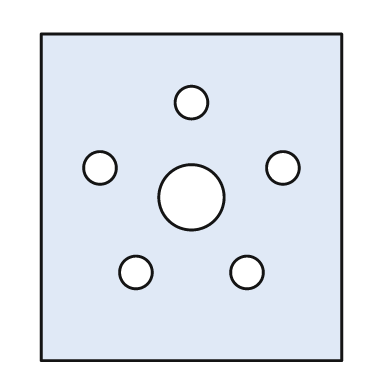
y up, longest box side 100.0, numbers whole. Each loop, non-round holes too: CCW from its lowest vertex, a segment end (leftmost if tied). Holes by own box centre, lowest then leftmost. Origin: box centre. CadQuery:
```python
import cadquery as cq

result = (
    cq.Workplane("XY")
    .moveTo(-46.0, -50.0)
    .lineTo(46.0, -50.0)
    .lineTo(46.0, 50.0)
    .lineTo(-46.0, 50.0)
    .close()
    .moveTo(-17.0, -23.0)
    .circle(5.0)
    .moveTo(17.0, -23.0)
    .circle(5.0)
    .moveTo(0.0, 0.0)
    .circle(10.0)
    .moveTo(-28.0, 9.0)
    .circle(5.0)
    .moveTo(28.0, 9.0)
    .circle(5.0)
    .moveTo(0.0, 29.0)
    .circle(5.0)
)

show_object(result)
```